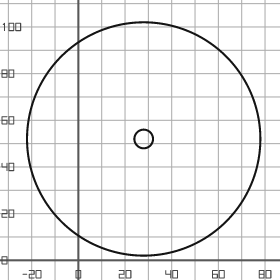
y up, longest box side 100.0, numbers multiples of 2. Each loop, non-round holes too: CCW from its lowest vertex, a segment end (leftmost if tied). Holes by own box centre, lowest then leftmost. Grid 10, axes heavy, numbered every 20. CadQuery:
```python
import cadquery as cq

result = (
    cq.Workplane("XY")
    .moveTo(28.0, 52.0)
    .circle(50.0)
    .moveTo(28.0, 52.0)
    .circle(4.0)
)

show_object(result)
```